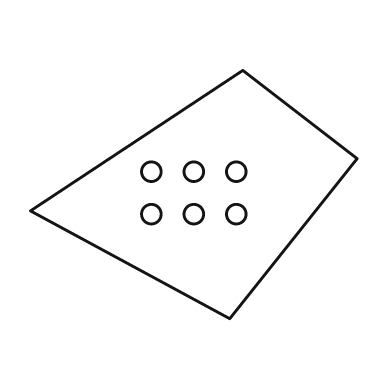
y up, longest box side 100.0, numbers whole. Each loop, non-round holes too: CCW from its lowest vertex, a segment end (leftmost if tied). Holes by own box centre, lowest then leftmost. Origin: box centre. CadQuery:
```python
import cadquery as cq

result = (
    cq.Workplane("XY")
    .moveTo(11.0, -38.0)
    .lineTo(50.0, 11.0)
    .lineTo(15.0, 38.0)
    .lineTo(-50.0, -5.0)
    .close()
    .moveTo(-13.0, -6.0)
    .circle(3.0)
    .moveTo(0.0, -6.0)
    .circle(3.0)
    .moveTo(13.0, -6.0)
    .circle(3.0)
    .moveTo(-13.0, 7.0)
    .circle(3.0)
    .moveTo(0.0, 7.0)
    .circle(3.0)
    .moveTo(13.0, 7.0)
    .circle(3.0)
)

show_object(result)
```